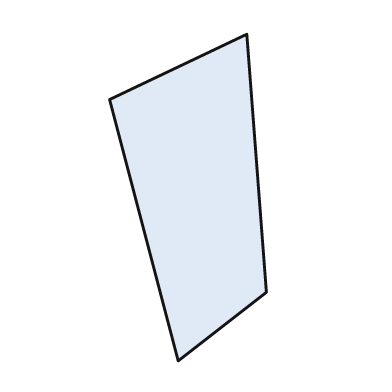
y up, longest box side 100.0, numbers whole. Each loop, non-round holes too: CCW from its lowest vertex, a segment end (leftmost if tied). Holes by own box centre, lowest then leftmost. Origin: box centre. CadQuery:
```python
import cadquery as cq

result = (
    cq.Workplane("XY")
    .moveTo(-3.0, -50.0)
    .lineTo(24.0, -29.0)
    .lineTo(18.0, 50.0)
    .lineTo(-24.0, 30.0)
    .close()
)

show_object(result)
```